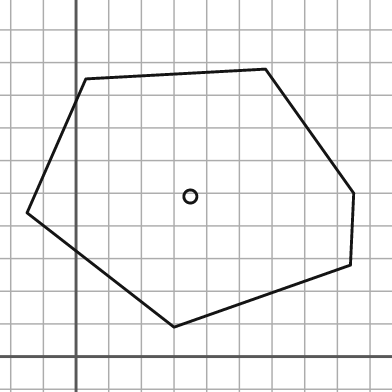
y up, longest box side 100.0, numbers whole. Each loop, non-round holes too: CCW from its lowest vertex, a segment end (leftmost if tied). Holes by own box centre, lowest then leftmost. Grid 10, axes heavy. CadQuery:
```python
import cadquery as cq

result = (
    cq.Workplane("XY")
    .moveTo(30.0, 9.0)
    .lineTo(84.0, 28.0)
    .lineTo(85.0, 50.0)
    .lineTo(58.0, 88.0)
    .lineTo(3.0, 85.0)
    .lineTo(-15.0, 44.0)
    .close()
    .moveTo(35.0, 49.0)
    .circle(2.0)
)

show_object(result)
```